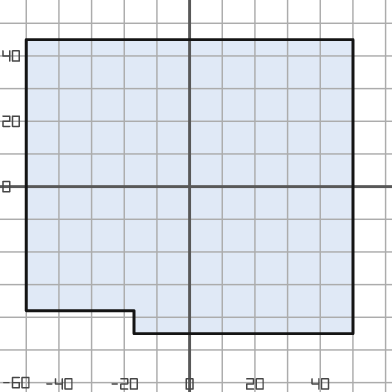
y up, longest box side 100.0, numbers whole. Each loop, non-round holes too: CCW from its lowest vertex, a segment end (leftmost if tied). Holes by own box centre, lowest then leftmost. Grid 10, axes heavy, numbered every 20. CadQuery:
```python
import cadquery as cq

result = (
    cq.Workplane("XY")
    .moveTo(-17.0, -45.0)
    .lineTo(50.0, -45.0)
    .lineTo(50.0, 45.0)
    .lineTo(-50.0, 45.0)
    .lineTo(-50.0, -38.0)
    .lineTo(-17.0, -38.0)
    .close()
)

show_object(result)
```